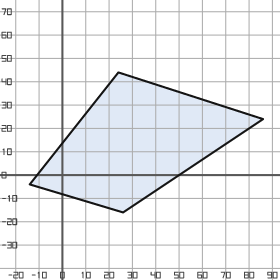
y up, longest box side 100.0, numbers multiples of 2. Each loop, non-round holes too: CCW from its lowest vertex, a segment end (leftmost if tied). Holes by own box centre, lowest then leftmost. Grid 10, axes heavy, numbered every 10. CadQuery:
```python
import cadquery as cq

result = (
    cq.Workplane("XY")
    .moveTo(26.0, -16.0)
    .lineTo(86.0, 24.0)
    .lineTo(24.0, 44.0)
    .lineTo(-14.0, -4.0)
    .close()
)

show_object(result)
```